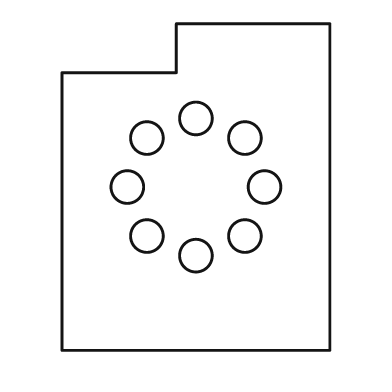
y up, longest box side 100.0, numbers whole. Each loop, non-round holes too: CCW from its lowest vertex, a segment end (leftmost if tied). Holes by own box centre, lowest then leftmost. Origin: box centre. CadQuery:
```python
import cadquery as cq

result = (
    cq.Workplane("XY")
    .moveTo(-41.0, -50.0)
    .lineTo(41.0, -50.0)
    .lineTo(41.0, 50.0)
    .lineTo(-6.0, 50.0)
    .lineTo(-6.0, 35.0)
    .lineTo(-41.0, 35.0)
    .close()
    .moveTo(0.0, -21.0)
    .circle(5.0)
    .moveTo(-15.0, -15.0)
    .circle(5.0)
    .moveTo(15.0, -15.0)
    .circle(5.0)
    .moveTo(-21.0, 0.0)
    .circle(5.0)
    .moveTo(21.0, 0.0)
    .circle(5.0)
    .moveTo(-15.0, 15.0)
    .circle(5.0)
    .moveTo(15.0, 15.0)
    .circle(5.0)
    .moveTo(0.0, 21.0)
    .circle(5.0)
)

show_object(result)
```